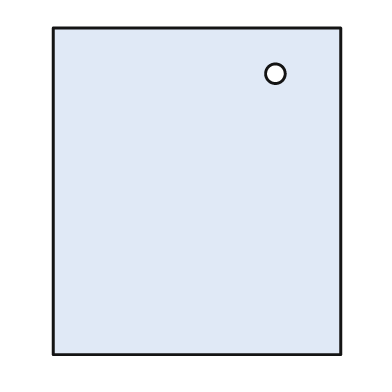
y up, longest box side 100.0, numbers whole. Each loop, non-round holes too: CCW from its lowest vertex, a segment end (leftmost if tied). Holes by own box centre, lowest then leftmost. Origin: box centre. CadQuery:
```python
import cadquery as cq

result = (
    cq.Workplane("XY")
    .moveTo(-44.0, -50.0)
    .lineTo(44.0, -50.0)
    .lineTo(44.0, 50.0)
    .lineTo(-44.0, 50.0)
    .close()
    .moveTo(24.0, 36.0)
    .circle(3.0)
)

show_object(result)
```